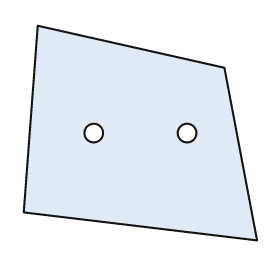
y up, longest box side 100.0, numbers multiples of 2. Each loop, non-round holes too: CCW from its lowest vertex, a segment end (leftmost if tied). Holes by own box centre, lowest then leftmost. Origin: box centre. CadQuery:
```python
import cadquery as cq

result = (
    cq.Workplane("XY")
    .moveTo(50.0, -46.0)
    .lineTo(36.0, 28.0)
    .lineTo(-44.0, 46.0)
    .lineTo(-50.0, -34.0)
    .close()
    .moveTo(-20.0, 0.0)
    .circle(4.0)
    .moveTo(20.0, 0.0)
    .circle(4.0)
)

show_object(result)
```